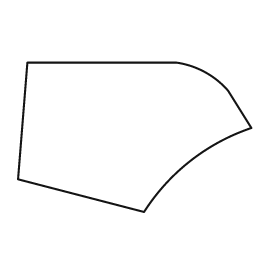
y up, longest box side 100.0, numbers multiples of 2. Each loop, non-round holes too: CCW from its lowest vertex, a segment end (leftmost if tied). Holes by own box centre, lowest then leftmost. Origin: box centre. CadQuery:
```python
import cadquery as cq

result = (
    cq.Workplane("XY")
    .moveTo(4.0, -32.0)
    .threePointArc((24.0, -10.0), (50.0, 4.0))
    .lineTo(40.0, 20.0)
    .threePointArc((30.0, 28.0), (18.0, 32.0))
    .lineTo(-46.0, 32.0)
    .lineTo(-50.0, -18.0)
    .close()
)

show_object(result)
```